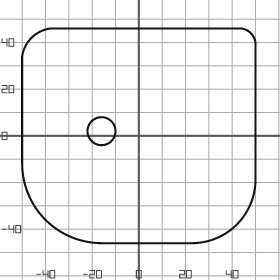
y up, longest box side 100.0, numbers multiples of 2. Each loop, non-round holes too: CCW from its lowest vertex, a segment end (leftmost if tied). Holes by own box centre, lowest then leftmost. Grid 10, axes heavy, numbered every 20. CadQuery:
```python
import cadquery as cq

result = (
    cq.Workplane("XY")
    .moveTo(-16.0, -46.0)
    .lineTo(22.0, -46.0)
    .threePointArc((42.0, -38.0), (50.0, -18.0))
    .lineTo(50.0, 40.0)
    .threePointArc((48.0, 44.0), (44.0, 46.0))
    .lineTo(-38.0, 46.0)
    .threePointArc((-46.0, 42.0), (-50.0, 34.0))
    .lineTo(-50.0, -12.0)
    .threePointArc((-40.0, -36.0), (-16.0, -46.0))
    .close()
    .moveTo(-16.0, 2.0)
    .circle(6.0)
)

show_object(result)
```